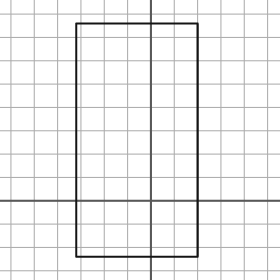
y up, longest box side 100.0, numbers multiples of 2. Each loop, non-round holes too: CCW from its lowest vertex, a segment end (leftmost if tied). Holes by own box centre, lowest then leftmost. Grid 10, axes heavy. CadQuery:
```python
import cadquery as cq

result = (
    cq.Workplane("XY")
    .moveTo(-32.0, -24.0)
    .lineTo(20.0, -24.0)
    .lineTo(20.0, 76.0)
    .lineTo(-32.0, 76.0)
    .close()
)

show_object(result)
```